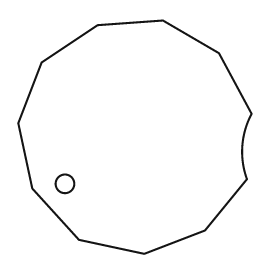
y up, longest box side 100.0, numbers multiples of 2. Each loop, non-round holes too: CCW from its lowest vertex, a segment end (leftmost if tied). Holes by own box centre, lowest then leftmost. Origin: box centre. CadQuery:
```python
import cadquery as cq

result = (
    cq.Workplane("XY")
    .moveTo(4.0, -50.0)
    .lineTo(30.0, -40.0)
    .lineTo(48.0, -18.0)
    .threePointArc((46.0, -4.0), (50.0, 10.0))
    .lineTo(36.0, 36.0)
    .lineTo(12.0, 50.0)
    .lineTo(-16.0, 48.0)
    .lineTo(-40.0, 32.0)
    .lineTo(-50.0, 6.0)
    .lineTo(-44.0, -22.0)
    .lineTo(-24.0, -44.0)
    .close()
    .moveTo(-30.0, -20.0)
    .circle(4.0)
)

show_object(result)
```